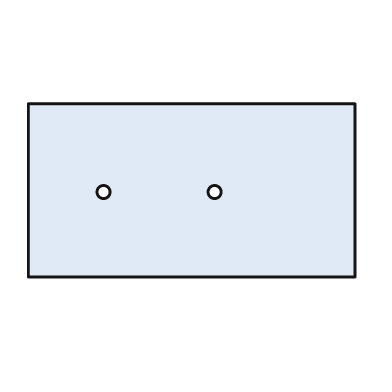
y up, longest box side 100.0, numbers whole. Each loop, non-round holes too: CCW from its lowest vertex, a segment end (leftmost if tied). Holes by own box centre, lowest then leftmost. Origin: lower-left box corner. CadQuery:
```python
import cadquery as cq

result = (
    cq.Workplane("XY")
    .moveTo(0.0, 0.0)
    .lineTo(100.0, 0.0)
    .lineTo(100.0, 53.0)
    .lineTo(0.0, 53.0)
    .close()
    .moveTo(23.0, 26.0)
    .circle(2.0)
    .moveTo(57.0, 26.0)
    .circle(2.0)
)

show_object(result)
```